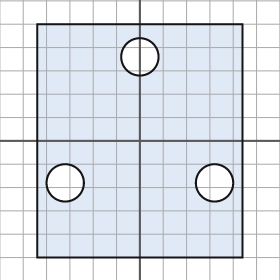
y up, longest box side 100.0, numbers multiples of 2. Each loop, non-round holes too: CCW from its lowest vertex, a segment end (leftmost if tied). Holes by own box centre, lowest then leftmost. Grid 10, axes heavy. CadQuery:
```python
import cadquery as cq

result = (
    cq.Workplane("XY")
    .moveTo(-44.0, -50.0)
    .lineTo(44.0, -50.0)
    .lineTo(44.0, 50.0)
    .lineTo(-44.0, 50.0)
    .close()
    .moveTo(-32.0, -18.0)
    .circle(8.0)
    .moveTo(32.0, -18.0)
    .circle(8.0)
    .moveTo(0.0, 36.0)
    .circle(8.0)
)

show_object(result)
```